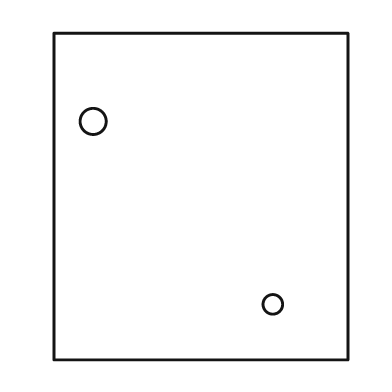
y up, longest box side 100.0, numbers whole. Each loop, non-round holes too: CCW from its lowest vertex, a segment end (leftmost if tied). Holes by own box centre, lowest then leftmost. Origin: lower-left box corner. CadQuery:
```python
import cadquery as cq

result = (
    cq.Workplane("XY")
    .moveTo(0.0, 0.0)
    .lineTo(90.0, 0.0)
    .lineTo(90.0, 100.0)
    .lineTo(0.0, 100.0)
    .close()
    .moveTo(67.0, 17.0)
    .circle(3.0)
    .moveTo(12.0, 73.0)
    .circle(4.0)
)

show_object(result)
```